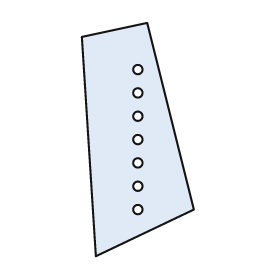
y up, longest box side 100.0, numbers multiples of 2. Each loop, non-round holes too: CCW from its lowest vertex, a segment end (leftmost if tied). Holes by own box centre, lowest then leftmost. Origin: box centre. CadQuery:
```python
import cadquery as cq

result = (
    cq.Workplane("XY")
    .moveTo(-18.0, -50.0)
    .lineTo(24.0, -30.0)
    .lineTo(4.0, 50.0)
    .lineTo(-24.0, 44.0)
    .close()
    .moveTo(0.0, -30.0)
    .circle(2.0)
    .moveTo(0.0, -20.0)
    .circle(2.0)
    .moveTo(0.0, -10.0)
    .circle(2.0)
    .moveTo(0.0, 0.0)
    .circle(2.0)
    .moveTo(0.0, 10.0)
    .circle(2.0)
    .moveTo(0.0, 20.0)
    .circle(2.0)
    .moveTo(0.0, 30.0)
    .circle(2.0)
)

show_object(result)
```